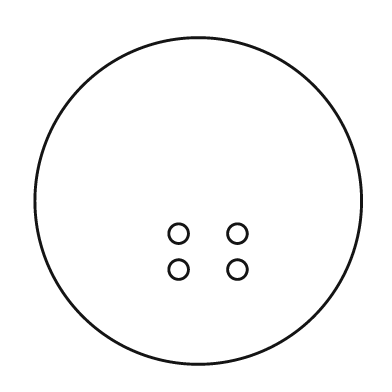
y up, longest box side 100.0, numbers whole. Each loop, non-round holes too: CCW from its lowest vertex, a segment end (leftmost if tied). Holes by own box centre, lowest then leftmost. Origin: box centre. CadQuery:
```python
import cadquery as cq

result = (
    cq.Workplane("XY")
    .moveTo(0.0, 0.0)
    .circle(50.0)
    .moveTo(-6.0, -21.0)
    .circle(3.0)
    .moveTo(12.0, -21.0)
    .circle(3.0)
    .moveTo(-6.0, -10.0)
    .circle(3.0)
    .moveTo(12.0, -10.0)
    .circle(3.0)
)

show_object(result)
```